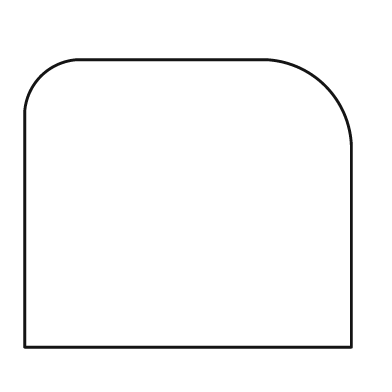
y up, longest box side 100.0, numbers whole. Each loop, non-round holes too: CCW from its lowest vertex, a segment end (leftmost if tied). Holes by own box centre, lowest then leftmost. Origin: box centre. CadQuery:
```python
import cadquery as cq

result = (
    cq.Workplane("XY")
    .moveTo(-50.0, -44.0)
    .lineTo(50.0, -44.0)
    .lineTo(50.0, 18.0)
    .threePointArc((42.0, 36.0), (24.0, 44.0))
    .lineTo(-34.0, 44.0)
    .threePointArc((-45.0, 39.0), (-50.0, 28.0))
    .close()
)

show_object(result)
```